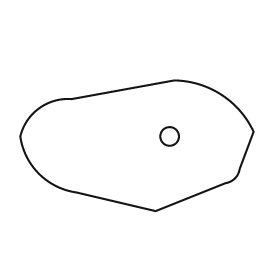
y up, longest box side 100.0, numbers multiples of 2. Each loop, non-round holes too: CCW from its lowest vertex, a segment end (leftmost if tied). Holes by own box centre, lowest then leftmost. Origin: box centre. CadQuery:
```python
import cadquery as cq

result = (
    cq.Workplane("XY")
    .moveTo(8.0, -28.0)
    .lineTo(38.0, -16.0)
    .threePointArc((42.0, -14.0), (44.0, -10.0))
    .lineTo(50.0, 6.0)
    .threePointArc((36.0, 22.0), (16.0, 28.0))
    .lineTo(-28.0, 20.0)
    .threePointArc((-42.0, 16.0), (-50.0, 4.0))
    .threePointArc((-42.0, -12.0), (-26.0, -20.0))
    .close()
    .moveTo(14.0, 4.0)
    .circle(4.0)
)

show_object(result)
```